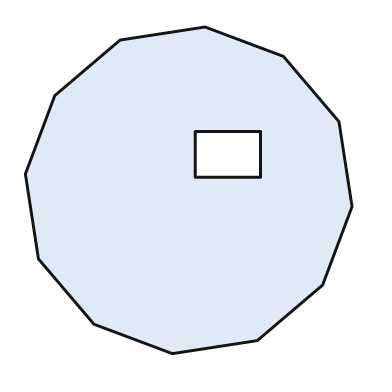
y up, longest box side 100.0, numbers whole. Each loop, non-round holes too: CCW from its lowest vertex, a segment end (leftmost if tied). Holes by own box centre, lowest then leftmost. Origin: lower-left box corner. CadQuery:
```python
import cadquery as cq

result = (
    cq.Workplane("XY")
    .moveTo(45.0, 0.0)
    .lineTo(71.0, 4.0)
    .lineTo(91.0, 21.0)
    .lineTo(100.0, 45.0)
    .lineTo(96.0, 71.0)
    .lineTo(79.0, 91.0)
    .lineTo(55.0, 100.0)
    .lineTo(29.0, 96.0)
    .lineTo(9.0, 79.0)
    .lineTo(0.0, 55.0)
    .lineTo(4.0, 29.0)
    .lineTo(21.0, 9.0)
    .close()
    .moveTo(52.0, 54.0)
    .lineTo(72.0, 54.0)
    .lineTo(72.0, 68.0)
    .lineTo(52.0, 68.0)
    .close()
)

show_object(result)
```